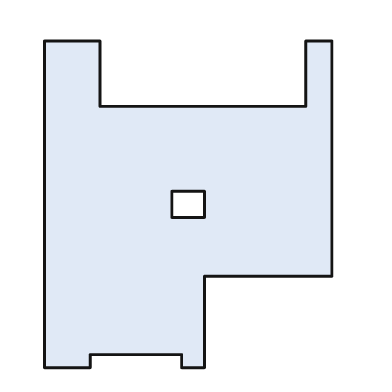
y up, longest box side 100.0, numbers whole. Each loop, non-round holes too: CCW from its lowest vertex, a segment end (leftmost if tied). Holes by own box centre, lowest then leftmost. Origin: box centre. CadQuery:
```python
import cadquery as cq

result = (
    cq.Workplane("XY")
    .moveTo(-44.0, -50.0)
    .lineTo(-30.0, -50.0)
    .lineTo(-30.0, -46.0)
    .lineTo(-2.0, -46.0)
    .lineTo(-2.0, -50.0)
    .lineTo(5.0, -50.0)
    .lineTo(5.0, -22.0)
    .lineTo(44.0, -22.0)
    .lineTo(44.0, 50.0)
    .lineTo(36.0, 50.0)
    .lineTo(36.0, 30.0)
    .lineTo(-27.0, 30.0)
    .lineTo(-27.0, 50.0)
    .lineTo(-44.0, 50.0)
    .close()
    .moveTo(-5.0, -4.0)
    .lineTo(5.0, -4.0)
    .lineTo(5.0, 4.0)
    .lineTo(-5.0, 4.0)
    .close()
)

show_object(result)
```